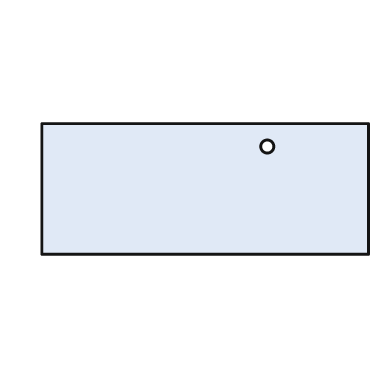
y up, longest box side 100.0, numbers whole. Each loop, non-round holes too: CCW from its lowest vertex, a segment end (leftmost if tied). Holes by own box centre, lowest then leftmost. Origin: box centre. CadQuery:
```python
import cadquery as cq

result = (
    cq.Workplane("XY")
    .moveTo(-50.0, -20.0)
    .lineTo(50.0, -20.0)
    .lineTo(50.0, 20.0)
    .lineTo(-50.0, 20.0)
    .close()
    .moveTo(19.0, 13.0)
    .circle(2.0)
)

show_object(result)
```